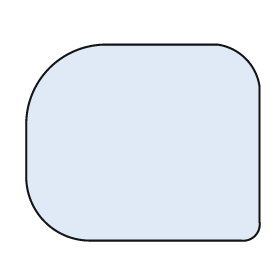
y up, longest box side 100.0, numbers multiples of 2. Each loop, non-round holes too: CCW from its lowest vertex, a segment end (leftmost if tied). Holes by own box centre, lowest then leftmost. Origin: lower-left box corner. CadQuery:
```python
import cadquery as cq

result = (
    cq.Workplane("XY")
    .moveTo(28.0, 0.0)
    .lineTo(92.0, 0.0)
    .threePointArc((98.0, 2.0), (100.0, 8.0))
    .lineTo(100.0, 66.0)
    .threePointArc((94.0, 78.0), (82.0, 84.0))
    .lineTo(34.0, 84.0)
    .threePointArc((10.0, 74.0), (0.0, 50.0))
    .lineTo(0.0, 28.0)
    .threePointArc((8.0, 8.0), (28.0, 0.0))
    .close()
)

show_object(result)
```